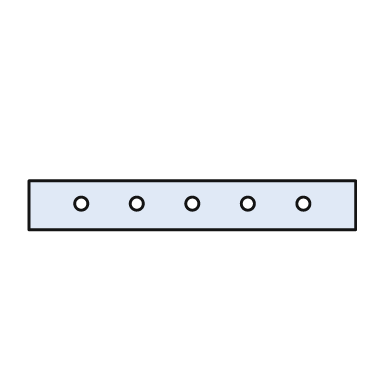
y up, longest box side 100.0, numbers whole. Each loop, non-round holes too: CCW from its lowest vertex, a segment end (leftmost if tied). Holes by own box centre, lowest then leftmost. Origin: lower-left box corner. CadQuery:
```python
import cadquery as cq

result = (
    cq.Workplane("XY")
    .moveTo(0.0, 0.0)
    .lineTo(100.0, 0.0)
    .lineTo(100.0, 15.0)
    .lineTo(0.0, 15.0)
    .close()
    .moveTo(16.0, 8.0)
    .circle(2.0)
    .moveTo(33.0, 8.0)
    .circle(2.0)
    .moveTo(50.0, 8.0)
    .circle(2.0)
    .moveTo(67.0, 8.0)
    .circle(2.0)
    .moveTo(84.0, 8.0)
    .circle(2.0)
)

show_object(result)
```